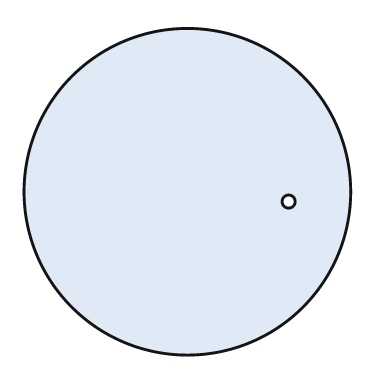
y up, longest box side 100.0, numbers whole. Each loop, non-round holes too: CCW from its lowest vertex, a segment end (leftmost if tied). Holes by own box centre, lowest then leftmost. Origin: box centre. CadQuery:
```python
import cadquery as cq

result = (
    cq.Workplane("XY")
    .moveTo(0.0, 0.0)
    .circle(50.0)
    .moveTo(31.0, -3.0)
    .circle(2.0)
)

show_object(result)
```